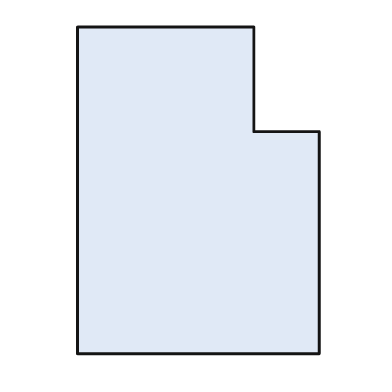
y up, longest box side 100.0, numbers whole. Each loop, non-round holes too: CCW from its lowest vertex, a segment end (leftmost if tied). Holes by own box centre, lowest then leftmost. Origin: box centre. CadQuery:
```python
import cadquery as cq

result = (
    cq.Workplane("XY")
    .moveTo(-37.0, -50.0)
    .lineTo(37.0, -50.0)
    .lineTo(37.0, 18.0)
    .lineTo(17.0, 18.0)
    .lineTo(17.0, 50.0)
    .lineTo(-37.0, 50.0)
    .close()
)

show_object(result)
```